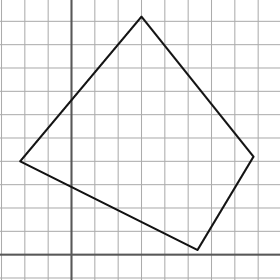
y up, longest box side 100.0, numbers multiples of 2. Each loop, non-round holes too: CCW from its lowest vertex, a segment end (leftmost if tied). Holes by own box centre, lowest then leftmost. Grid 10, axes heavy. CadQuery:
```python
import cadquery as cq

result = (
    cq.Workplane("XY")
    .moveTo(54.0, 2.0)
    .lineTo(78.0, 42.0)
    .lineTo(30.0, 102.0)
    .lineTo(-22.0, 40.0)
    .close()
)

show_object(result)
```